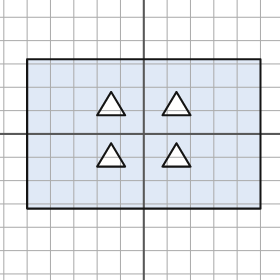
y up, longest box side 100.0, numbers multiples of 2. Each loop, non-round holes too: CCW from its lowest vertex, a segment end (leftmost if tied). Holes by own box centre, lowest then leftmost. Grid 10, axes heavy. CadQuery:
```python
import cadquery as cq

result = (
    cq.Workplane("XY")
    .moveTo(-50.0, -32.0)
    .lineTo(50.0, -32.0)
    .lineTo(50.0, 32.0)
    .lineTo(-50.0, 32.0)
    .close()
    .moveTo(-20.0, -14.0)
    .lineTo(-8.0, -14.0)
    .lineTo(-14.0, -4.0)
    .close()
    .moveTo(8.0, -14.0)
    .lineTo(20.0, -14.0)
    .lineTo(14.0, -4.0)
    .close()
    .moveTo(-20.0, 8.0)
    .lineTo(-8.0, 8.0)
    .lineTo(-14.0, 18.0)
    .close()
    .moveTo(8.0, 8.0)
    .lineTo(20.0, 8.0)
    .lineTo(14.0, 18.0)
    .close()
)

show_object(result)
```